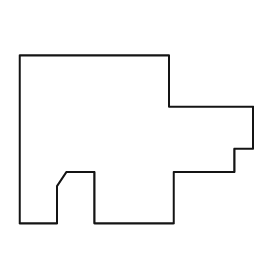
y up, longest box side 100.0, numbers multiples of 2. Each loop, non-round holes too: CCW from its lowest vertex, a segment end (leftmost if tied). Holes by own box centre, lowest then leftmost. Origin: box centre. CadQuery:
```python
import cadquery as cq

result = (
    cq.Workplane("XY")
    .moveTo(-50.0, -36.0)
    .lineTo(-34.0, -36.0)
    .lineTo(-34.0, -20.0)
    .lineTo(-30.0, -14.0)
    .lineTo(-18.0, -14.0)
    .lineTo(-18.0, -36.0)
    .lineTo(16.0, -36.0)
    .lineTo(16.0, -14.0)
    .lineTo(42.0, -14.0)
    .lineTo(42.0, -4.0)
    .lineTo(50.0, -4.0)
    .lineTo(50.0, 14.0)
    .lineTo(14.0, 14.0)
    .lineTo(14.0, 36.0)
    .lineTo(-50.0, 36.0)
    .close()
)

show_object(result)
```